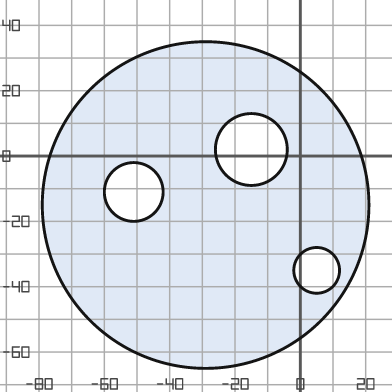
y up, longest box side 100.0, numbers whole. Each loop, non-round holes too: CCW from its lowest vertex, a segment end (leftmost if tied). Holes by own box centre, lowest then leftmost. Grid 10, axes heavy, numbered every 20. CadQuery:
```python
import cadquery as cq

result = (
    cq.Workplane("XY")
    .moveTo(-29.0, -15.0)
    .circle(50.0)
    .moveTo(5.0, -35.0)
    .circle(7.0)
    .moveTo(-51.0, -11.0)
    .circle(9.0)
    .moveTo(-15.0, 2.0)
    .circle(11.0)
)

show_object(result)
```